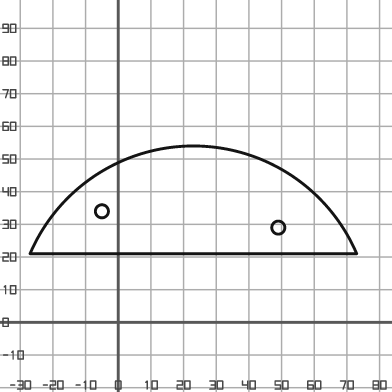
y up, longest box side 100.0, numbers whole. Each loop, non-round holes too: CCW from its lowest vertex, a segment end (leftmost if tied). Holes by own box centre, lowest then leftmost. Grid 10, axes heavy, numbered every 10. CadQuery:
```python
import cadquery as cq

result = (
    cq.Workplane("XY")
    .moveTo(-27.0, 21.0)
    .lineTo(73.0, 21.0)
    .threePointArc((23.0, 54.0), (-27.0, 21.0))
    .close()
    .moveTo(49.0, 29.0)
    .circle(2.0)
    .moveTo(-5.0, 34.0)
    .circle(2.0)
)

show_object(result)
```